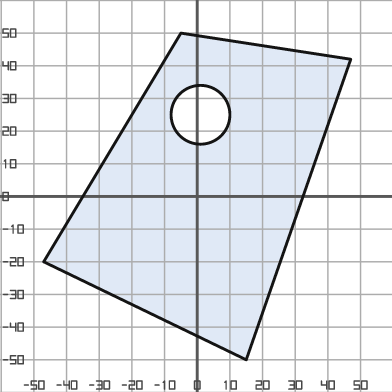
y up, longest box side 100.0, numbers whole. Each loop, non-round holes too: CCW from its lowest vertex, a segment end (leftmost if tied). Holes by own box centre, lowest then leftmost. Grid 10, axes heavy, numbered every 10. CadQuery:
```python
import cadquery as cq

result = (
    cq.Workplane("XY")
    .moveTo(15.0, -50.0)
    .lineTo(47.0, 42.0)
    .lineTo(-5.0, 50.0)
    .lineTo(-47.0, -20.0)
    .close()
    .moveTo(1.0, 25.0)
    .circle(9.0)
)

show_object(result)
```